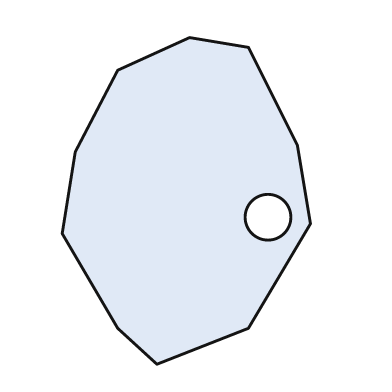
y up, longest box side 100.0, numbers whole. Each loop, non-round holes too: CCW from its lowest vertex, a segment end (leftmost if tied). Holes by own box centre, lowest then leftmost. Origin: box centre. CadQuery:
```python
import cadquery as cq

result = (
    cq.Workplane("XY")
    .moveTo(-9.0, -50.0)
    .lineTo(19.0, -39.0)
    .lineTo(38.0, -7.0)
    .lineTo(34.0, 17.0)
    .lineTo(19.0, 47.0)
    .lineTo(1.0, 50.0)
    .lineTo(-21.0, 40.0)
    .lineTo(-34.0, 15.0)
    .lineTo(-38.0, -10.0)
    .lineTo(-21.0, -39.0)
    .close()
    .moveTo(25.0, -5.0)
    .circle(7.0)
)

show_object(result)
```